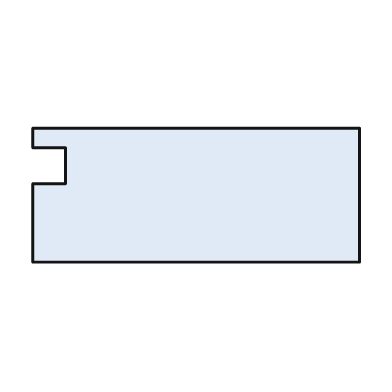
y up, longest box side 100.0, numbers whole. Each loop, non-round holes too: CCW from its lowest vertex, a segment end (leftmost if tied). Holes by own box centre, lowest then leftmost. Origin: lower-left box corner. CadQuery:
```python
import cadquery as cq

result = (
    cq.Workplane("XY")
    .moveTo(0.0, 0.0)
    .lineTo(100.0, 0.0)
    .lineTo(100.0, 41.0)
    .lineTo(0.0, 41.0)
    .lineTo(0.0, 35.0)
    .lineTo(10.0, 35.0)
    .lineTo(10.0, 24.0)
    .lineTo(0.0, 24.0)
    .close()
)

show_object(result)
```